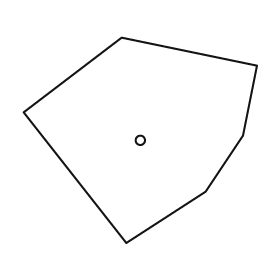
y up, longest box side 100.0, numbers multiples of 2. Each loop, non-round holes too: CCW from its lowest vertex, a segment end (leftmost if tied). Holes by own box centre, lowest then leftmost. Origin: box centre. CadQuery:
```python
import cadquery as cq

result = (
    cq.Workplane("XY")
    .moveTo(-6.0, -44.0)
    .lineTo(28.0, -22.0)
    .lineTo(44.0, 2.0)
    .lineTo(50.0, 32.0)
    .lineTo(-8.0, 44.0)
    .lineTo(-50.0, 12.0)
    .close()
    .moveTo(0.0, 0.0)
    .circle(2.0)
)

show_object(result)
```